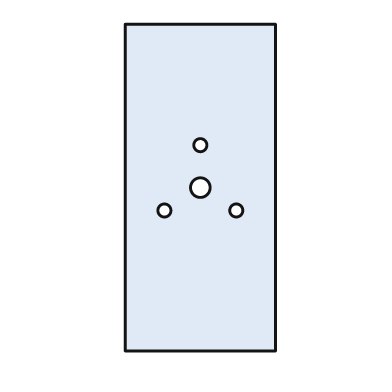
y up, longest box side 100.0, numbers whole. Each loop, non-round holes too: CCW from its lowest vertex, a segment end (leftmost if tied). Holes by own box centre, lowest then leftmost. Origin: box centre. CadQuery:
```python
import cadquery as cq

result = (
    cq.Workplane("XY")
    .moveTo(-23.0, -50.0)
    .lineTo(23.0, -50.0)
    .lineTo(23.0, 50.0)
    .lineTo(-23.0, 50.0)
    .close()
    .moveTo(-11.0, -7.0)
    .circle(2.0)
    .moveTo(11.0, -7.0)
    .circle(2.0)
    .moveTo(0.0, 0.0)
    .circle(3.0)
    .moveTo(0.0, 13.0)
    .circle(2.0)
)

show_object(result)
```